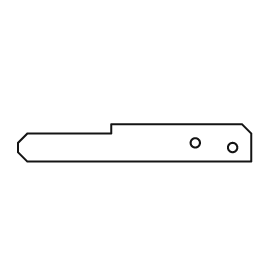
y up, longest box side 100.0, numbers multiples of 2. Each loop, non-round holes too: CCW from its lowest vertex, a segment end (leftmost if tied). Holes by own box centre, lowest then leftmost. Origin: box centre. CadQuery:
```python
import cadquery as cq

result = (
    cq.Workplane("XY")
    .moveTo(-46.0, -8.0)
    .lineTo(50.0, -8.0)
    .lineTo(50.0, 4.0)
    .lineTo(46.0, 8.0)
    .lineTo(-10.0, 8.0)
    .lineTo(-10.0, 4.0)
    .lineTo(-46.0, 4.0)
    .lineTo(-50.0, 0.0)
    .lineTo(-50.0, -4.0)
    .close()
    .moveTo(42.0, -2.0)
    .circle(2.0)
    .moveTo(26.0, 0.0)
    .circle(2.0)
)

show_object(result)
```